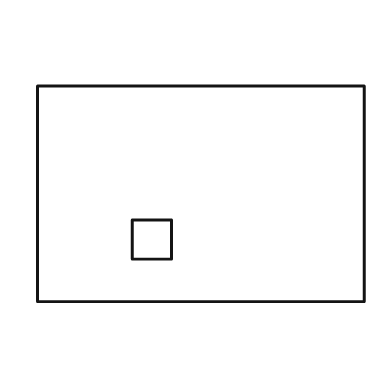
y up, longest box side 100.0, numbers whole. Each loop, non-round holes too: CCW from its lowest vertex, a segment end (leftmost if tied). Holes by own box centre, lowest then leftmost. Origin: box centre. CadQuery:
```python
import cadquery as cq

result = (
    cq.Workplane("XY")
    .moveTo(-50.0, -33.0)
    .lineTo(50.0, -33.0)
    .lineTo(50.0, 33.0)
    .lineTo(-50.0, 33.0)
    .close()
    .moveTo(-21.0, -20.0)
    .lineTo(-9.0, -20.0)
    .lineTo(-9.0, -8.0)
    .lineTo(-21.0, -8.0)
    .close()
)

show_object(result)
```